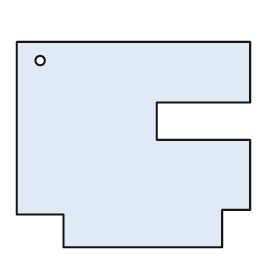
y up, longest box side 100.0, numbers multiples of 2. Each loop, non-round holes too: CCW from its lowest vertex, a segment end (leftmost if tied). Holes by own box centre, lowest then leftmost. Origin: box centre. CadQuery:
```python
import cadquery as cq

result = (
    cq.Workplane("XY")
    .moveTo(-30.0, -44.0)
    .lineTo(38.0, -44.0)
    .lineTo(38.0, -28.0)
    .lineTo(50.0, -28.0)
    .lineTo(50.0, 2.0)
    .lineTo(10.0, 2.0)
    .lineTo(10.0, 18.0)
    .lineTo(50.0, 18.0)
    .lineTo(50.0, 44.0)
    .lineTo(-50.0, 44.0)
    .lineTo(-50.0, -30.0)
    .lineTo(-30.0, -30.0)
    .close()
    .moveTo(-40.0, 36.0)
    .circle(2.0)
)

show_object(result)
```